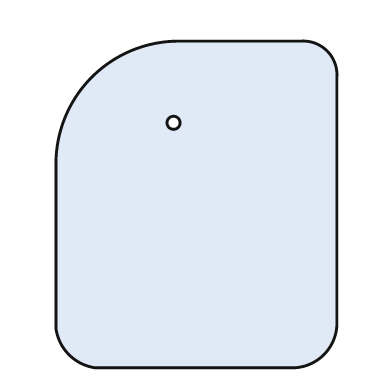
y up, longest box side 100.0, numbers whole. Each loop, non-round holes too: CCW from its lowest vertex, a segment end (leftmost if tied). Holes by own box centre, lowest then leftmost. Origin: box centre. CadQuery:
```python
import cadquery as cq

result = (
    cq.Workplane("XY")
    .moveTo(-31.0, -50.0)
    .lineTo(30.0, -50.0)
    .threePointArc((39.0, -46.0), (43.0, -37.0))
    .lineTo(43.0, 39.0)
    .threePointArc((40.0, 47.0), (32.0, 50.0))
    .lineTo(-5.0, 50.0)
    .threePointArc((-32.0, 39.0), (-43.0, 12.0))
    .lineTo(-43.0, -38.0)
    .threePointArc((-39.0, -46.0), (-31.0, -50.0))
    .close()
    .moveTo(-7.0, 25.0)
    .circle(2.0)
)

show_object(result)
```